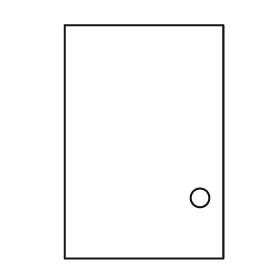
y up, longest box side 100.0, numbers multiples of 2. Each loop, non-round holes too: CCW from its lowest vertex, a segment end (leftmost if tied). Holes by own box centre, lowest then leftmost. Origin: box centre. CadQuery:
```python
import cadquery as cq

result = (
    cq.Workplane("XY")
    .moveTo(-34.0, -50.0)
    .lineTo(34.0, -50.0)
    .lineTo(34.0, 50.0)
    .lineTo(-34.0, 50.0)
    .close()
    .moveTo(24.0, -24.0)
    .circle(4.0)
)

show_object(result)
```